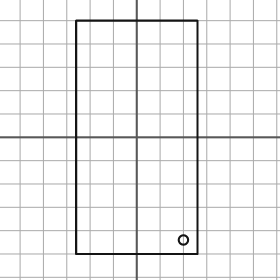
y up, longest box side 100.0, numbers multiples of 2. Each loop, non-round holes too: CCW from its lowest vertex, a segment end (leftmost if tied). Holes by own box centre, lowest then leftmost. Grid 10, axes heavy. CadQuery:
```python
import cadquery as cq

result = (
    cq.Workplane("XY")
    .moveTo(-26.0, -50.0)
    .lineTo(26.0, -50.0)
    .lineTo(26.0, 50.0)
    .lineTo(-26.0, 50.0)
    .close()
    .moveTo(20.0, -44.0)
    .circle(2.0)
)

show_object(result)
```